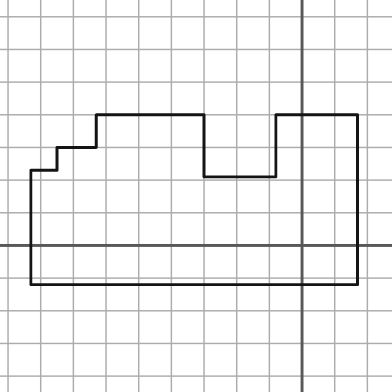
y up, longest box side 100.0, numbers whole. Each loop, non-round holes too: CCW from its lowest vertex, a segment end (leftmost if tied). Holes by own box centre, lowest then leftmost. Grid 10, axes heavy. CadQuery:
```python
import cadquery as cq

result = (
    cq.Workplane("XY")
    .moveTo(-83.0, -12.0)
    .lineTo(17.0, -12.0)
    .lineTo(17.0, 40.0)
    .lineTo(-8.0, 40.0)
    .lineTo(-8.0, 21.0)
    .lineTo(-30.0, 21.0)
    .lineTo(-30.0, 40.0)
    .lineTo(-63.0, 40.0)
    .lineTo(-63.0, 30.0)
    .lineTo(-75.0, 30.0)
    .lineTo(-75.0, 23.0)
    .lineTo(-83.0, 23.0)
    .close()
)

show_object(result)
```